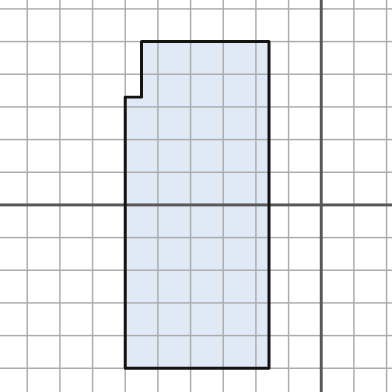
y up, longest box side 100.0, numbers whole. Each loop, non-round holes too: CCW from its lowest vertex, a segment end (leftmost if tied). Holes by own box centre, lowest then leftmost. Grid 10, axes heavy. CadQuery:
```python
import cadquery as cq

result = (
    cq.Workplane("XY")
    .moveTo(-60.0, -50.0)
    .lineTo(-16.0, -50.0)
    .lineTo(-16.0, 50.0)
    .lineTo(-55.0, 50.0)
    .lineTo(-55.0, 33.0)
    .lineTo(-60.0, 33.0)
    .close()
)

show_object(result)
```